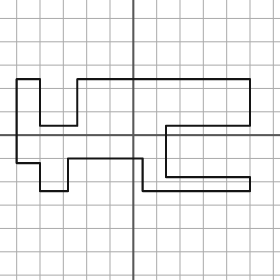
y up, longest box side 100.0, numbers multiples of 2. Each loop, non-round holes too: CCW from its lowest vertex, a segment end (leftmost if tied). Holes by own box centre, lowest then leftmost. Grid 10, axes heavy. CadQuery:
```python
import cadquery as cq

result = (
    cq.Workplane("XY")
    .moveTo(-40.0, -24.0)
    .lineTo(-28.0, -24.0)
    .lineTo(-28.0, -10.0)
    .lineTo(4.0, -10.0)
    .lineTo(4.0, -24.0)
    .lineTo(50.0, -24.0)
    .lineTo(50.0, -18.0)
    .lineTo(14.0, -18.0)
    .lineTo(14.0, 4.0)
    .lineTo(50.0, 4.0)
    .lineTo(50.0, 24.0)
    .lineTo(-24.0, 24.0)
    .lineTo(-24.0, 4.0)
    .lineTo(-40.0, 4.0)
    .lineTo(-40.0, 24.0)
    .lineTo(-50.0, 24.0)
    .lineTo(-50.0, -12.0)
    .lineTo(-40.0, -12.0)
    .close()
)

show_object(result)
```